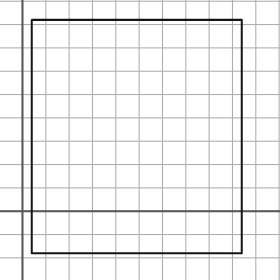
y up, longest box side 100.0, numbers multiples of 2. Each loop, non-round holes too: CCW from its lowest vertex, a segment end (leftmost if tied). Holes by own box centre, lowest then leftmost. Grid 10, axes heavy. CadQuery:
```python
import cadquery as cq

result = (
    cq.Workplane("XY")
    .moveTo(4.0, -18.0)
    .lineTo(94.0, -18.0)
    .lineTo(94.0, 82.0)
    .lineTo(4.0, 82.0)
    .close()
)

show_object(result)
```